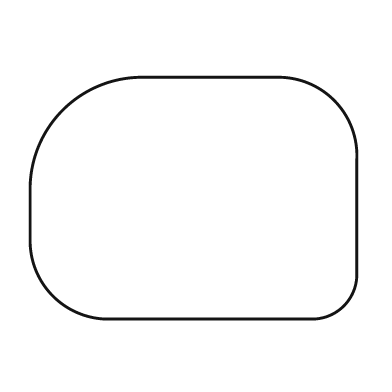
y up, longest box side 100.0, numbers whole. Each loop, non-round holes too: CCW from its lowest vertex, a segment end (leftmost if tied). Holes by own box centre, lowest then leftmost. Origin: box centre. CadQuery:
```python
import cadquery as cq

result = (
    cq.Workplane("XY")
    .moveTo(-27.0, -37.0)
    .lineTo(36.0, -37.0)
    .threePointArc((46.0, -33.0), (50.0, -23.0))
    .lineTo(50.0, 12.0)
    .threePointArc((43.0, 30.0), (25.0, 37.0))
    .lineTo(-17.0, 37.0)
    .threePointArc((-40.0, 27.0), (-50.0, 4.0))
    .lineTo(-50.0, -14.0)
    .threePointArc((-43.0, -30.0), (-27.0, -37.0))
    .close()
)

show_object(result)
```